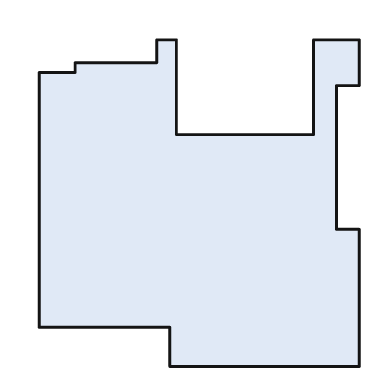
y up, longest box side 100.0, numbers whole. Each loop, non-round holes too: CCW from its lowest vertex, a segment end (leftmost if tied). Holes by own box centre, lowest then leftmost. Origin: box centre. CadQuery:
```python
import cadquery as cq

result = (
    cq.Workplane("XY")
    .moveTo(-9.0, -50.0)
    .lineTo(49.0, -50.0)
    .lineTo(49.0, -8.0)
    .lineTo(42.0, -8.0)
    .lineTo(42.0, 36.0)
    .lineTo(49.0, 36.0)
    .lineTo(49.0, 50.0)
    .lineTo(35.0, 50.0)
    .lineTo(35.0, 21.0)
    .lineTo(-7.0, 21.0)
    .lineTo(-7.0, 50.0)
    .lineTo(-13.0, 50.0)
    .lineTo(-13.0, 43.0)
    .lineTo(-38.0, 43.0)
    .lineTo(-38.0, 40.0)
    .lineTo(-49.0, 40.0)
    .lineTo(-49.0, -38.0)
    .lineTo(-9.0, -38.0)
    .close()
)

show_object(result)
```